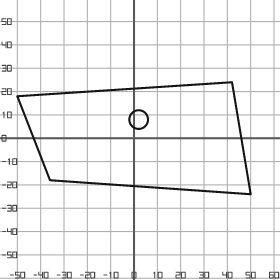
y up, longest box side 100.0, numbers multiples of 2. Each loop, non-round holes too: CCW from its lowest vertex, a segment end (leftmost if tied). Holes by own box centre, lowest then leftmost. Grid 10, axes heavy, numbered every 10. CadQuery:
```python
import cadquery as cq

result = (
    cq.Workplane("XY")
    .moveTo(50.0, -24.0)
    .lineTo(42.0, 24.0)
    .lineTo(-50.0, 18.0)
    .lineTo(-36.0, -18.0)
    .close()
    .moveTo(2.0, 8.0)
    .circle(4.0)
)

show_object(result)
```